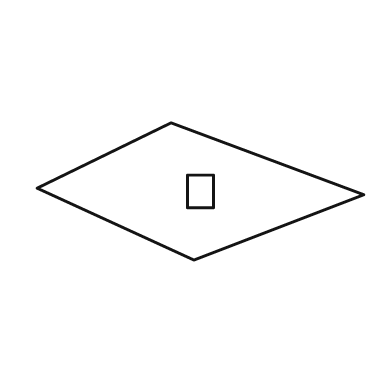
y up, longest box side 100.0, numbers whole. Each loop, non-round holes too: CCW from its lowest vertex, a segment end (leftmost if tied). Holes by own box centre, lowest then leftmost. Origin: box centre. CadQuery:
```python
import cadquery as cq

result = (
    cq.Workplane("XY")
    .moveTo(-2.0, -21.0)
    .lineTo(50.0, -1.0)
    .lineTo(-9.0, 21.0)
    .lineTo(-50.0, 1.0)
    .close()
    .moveTo(-4.0, -5.0)
    .lineTo(4.0, -5.0)
    .lineTo(4.0, 5.0)
    .lineTo(-4.0, 5.0)
    .close()
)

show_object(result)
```